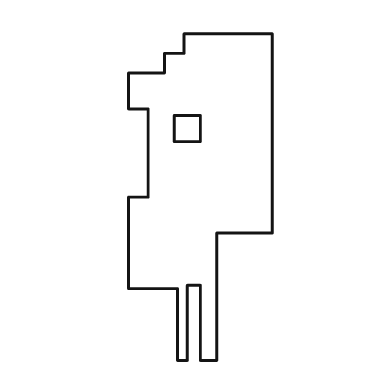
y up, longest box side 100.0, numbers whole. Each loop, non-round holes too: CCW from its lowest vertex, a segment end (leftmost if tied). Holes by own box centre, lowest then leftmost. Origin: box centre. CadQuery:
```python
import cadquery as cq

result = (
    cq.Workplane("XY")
    .moveTo(-7.0, -50.0)
    .lineTo(-4.0, -50.0)
    .lineTo(-4.0, -27.0)
    .lineTo(0.0, -27.0)
    .lineTo(0.0, -50.0)
    .lineTo(5.0, -50.0)
    .lineTo(5.0, -11.0)
    .lineTo(22.0, -11.0)
    .lineTo(22.0, 50.0)
    .lineTo(-5.0, 50.0)
    .lineTo(-5.0, 44.0)
    .lineTo(-11.0, 44.0)
    .lineTo(-11.0, 38.0)
    .lineTo(-22.0, 38.0)
    .lineTo(-22.0, 27.0)
    .lineTo(-16.0, 27.0)
    .lineTo(-16.0, 0.0)
    .lineTo(-22.0, 0.0)
    .lineTo(-22.0, -28.0)
    .lineTo(-7.0, -28.0)
    .close()
    .moveTo(-8.0, 17.0)
    .lineTo(0.0, 17.0)
    .lineTo(0.0, 25.0)
    .lineTo(-8.0, 25.0)
    .close()
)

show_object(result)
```